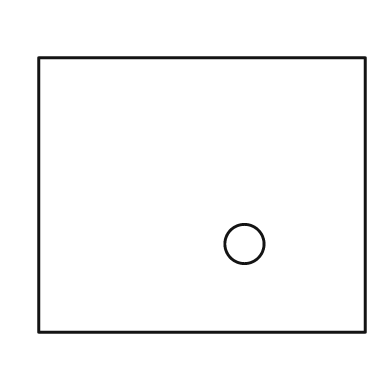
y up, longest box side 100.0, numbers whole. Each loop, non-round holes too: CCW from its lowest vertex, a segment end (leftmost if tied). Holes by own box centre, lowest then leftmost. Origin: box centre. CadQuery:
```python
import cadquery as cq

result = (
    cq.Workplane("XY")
    .moveTo(-50.0, -42.0)
    .lineTo(50.0, -42.0)
    .lineTo(50.0, 42.0)
    .lineTo(-50.0, 42.0)
    .close()
    .moveTo(13.0, -15.0)
    .circle(6.0)
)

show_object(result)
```